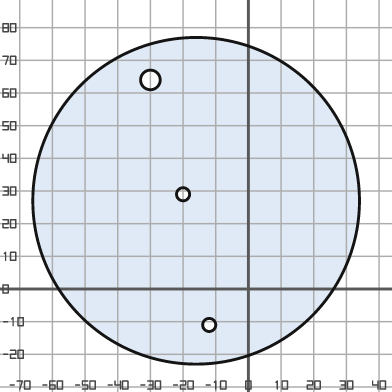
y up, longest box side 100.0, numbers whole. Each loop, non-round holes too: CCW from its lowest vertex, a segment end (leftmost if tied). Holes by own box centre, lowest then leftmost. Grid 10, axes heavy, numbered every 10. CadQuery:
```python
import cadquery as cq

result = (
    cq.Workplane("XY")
    .moveTo(-16.0, 27.0)
    .circle(50.0)
    .moveTo(-12.0, -11.0)
    .circle(2.0)
    .moveTo(-20.0, 29.0)
    .circle(2.0)
    .moveTo(-30.0, 64.0)
    .circle(3.0)
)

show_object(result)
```